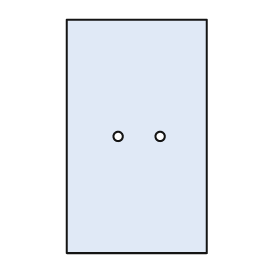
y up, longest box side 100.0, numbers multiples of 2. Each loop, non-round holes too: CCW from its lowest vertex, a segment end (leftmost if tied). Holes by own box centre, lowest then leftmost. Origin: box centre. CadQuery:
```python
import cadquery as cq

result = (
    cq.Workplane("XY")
    .moveTo(-30.0, -50.0)
    .lineTo(30.0, -50.0)
    .lineTo(30.0, 50.0)
    .lineTo(-30.0, 50.0)
    .close()
    .moveTo(-8.0, 0.0)
    .circle(2.0)
    .moveTo(10.0, 0.0)
    .circle(2.0)
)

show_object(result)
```